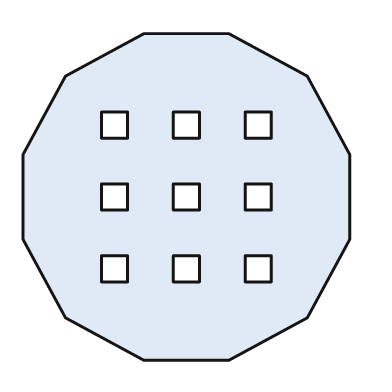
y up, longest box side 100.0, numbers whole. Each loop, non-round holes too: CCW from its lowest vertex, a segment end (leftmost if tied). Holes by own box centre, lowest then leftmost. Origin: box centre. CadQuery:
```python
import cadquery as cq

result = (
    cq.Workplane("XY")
    .moveTo(-13.0, -50.0)
    .lineTo(13.0, -50.0)
    .lineTo(37.0, -37.0)
    .lineTo(50.0, -13.0)
    .lineTo(50.0, 13.0)
    .lineTo(37.0, 37.0)
    .lineTo(13.0, 50.0)
    .lineTo(-13.0, 50.0)
    .lineTo(-37.0, 37.0)
    .lineTo(-50.0, 13.0)
    .lineTo(-50.0, -13.0)
    .lineTo(-37.0, -37.0)
    .close()
    .moveTo(-26.0, -26.0)
    .lineTo(-18.0, -26.0)
    .lineTo(-18.0, -18.0)
    .lineTo(-26.0, -18.0)
    .close()
    .moveTo(-4.0, -26.0)
    .lineTo(4.0, -26.0)
    .lineTo(4.0, -18.0)
    .lineTo(-4.0, -18.0)
    .close()
    .moveTo(18.0, -26.0)
    .lineTo(26.0, -26.0)
    .lineTo(26.0, -18.0)
    .lineTo(18.0, -18.0)
    .close()
    .moveTo(-26.0, -4.0)
    .lineTo(-18.0, -4.0)
    .lineTo(-18.0, 4.0)
    .lineTo(-26.0, 4.0)
    .close()
    .moveTo(-4.0, -4.0)
    .lineTo(4.0, -4.0)
    .lineTo(4.0, 4.0)
    .lineTo(-4.0, 4.0)
    .close()
    .moveTo(18.0, -4.0)
    .lineTo(26.0, -4.0)
    .lineTo(26.0, 4.0)
    .lineTo(18.0, 4.0)
    .close()
    .moveTo(-26.0, 18.0)
    .lineTo(-18.0, 18.0)
    .lineTo(-18.0, 26.0)
    .lineTo(-26.0, 26.0)
    .close()
    .moveTo(-4.0, 18.0)
    .lineTo(4.0, 18.0)
    .lineTo(4.0, 26.0)
    .lineTo(-4.0, 26.0)
    .close()
    .moveTo(18.0, 18.0)
    .lineTo(26.0, 18.0)
    .lineTo(26.0, 26.0)
    .lineTo(18.0, 26.0)
    .close()
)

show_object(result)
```